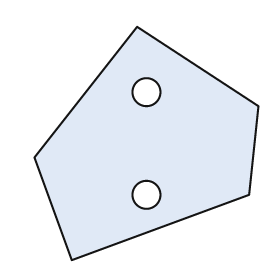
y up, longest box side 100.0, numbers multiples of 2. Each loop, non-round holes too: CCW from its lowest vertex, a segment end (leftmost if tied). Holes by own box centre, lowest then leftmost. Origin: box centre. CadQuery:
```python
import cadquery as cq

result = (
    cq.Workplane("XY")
    .moveTo(-32.0, -50.0)
    .lineTo(44.0, -22.0)
    .lineTo(48.0, 16.0)
    .lineTo(-4.0, 50.0)
    .lineTo(-48.0, -6.0)
    .close()
    .moveTo(0.0, -22.0)
    .circle(6.0)
    .moveTo(0.0, 22.0)
    .circle(6.0)
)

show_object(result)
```